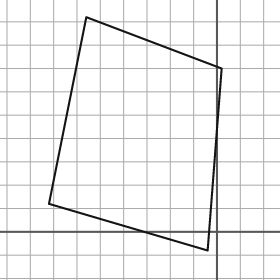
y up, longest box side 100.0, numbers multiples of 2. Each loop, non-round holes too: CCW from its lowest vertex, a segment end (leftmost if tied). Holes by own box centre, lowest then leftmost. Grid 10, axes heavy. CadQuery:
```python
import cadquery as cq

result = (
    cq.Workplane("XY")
    .moveTo(-4.0, -8.0)
    .lineTo(2.0, 70.0)
    .lineTo(-56.0, 92.0)
    .lineTo(-72.0, 12.0)
    .close()
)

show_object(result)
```